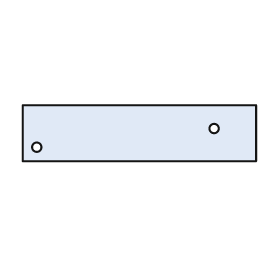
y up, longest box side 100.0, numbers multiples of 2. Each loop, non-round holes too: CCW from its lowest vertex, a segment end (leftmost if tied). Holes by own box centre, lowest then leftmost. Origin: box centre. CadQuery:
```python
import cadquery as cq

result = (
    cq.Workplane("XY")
    .moveTo(-50.0, -12.0)
    .lineTo(50.0, -12.0)
    .lineTo(50.0, 12.0)
    .lineTo(-50.0, 12.0)
    .close()
    .moveTo(-44.0, -6.0)
    .circle(2.0)
    .moveTo(32.0, 2.0)
    .circle(2.0)
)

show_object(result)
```